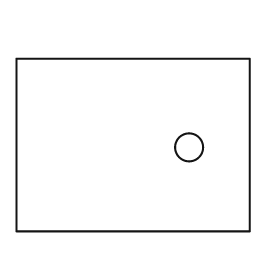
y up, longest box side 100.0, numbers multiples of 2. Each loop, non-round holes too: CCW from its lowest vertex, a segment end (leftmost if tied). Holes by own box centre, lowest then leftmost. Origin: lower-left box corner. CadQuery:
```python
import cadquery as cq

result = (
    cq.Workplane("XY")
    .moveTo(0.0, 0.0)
    .lineTo(100.0, 0.0)
    .lineTo(100.0, 74.0)
    .lineTo(0.0, 74.0)
    .close()
    .moveTo(74.0, 36.0)
    .circle(6.0)
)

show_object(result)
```